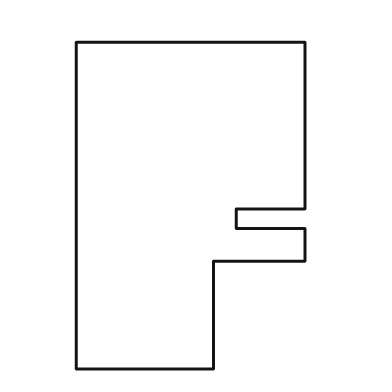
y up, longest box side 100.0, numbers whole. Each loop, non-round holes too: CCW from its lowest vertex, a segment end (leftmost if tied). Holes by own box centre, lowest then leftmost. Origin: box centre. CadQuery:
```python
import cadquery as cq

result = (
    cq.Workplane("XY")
    .moveTo(-35.0, -50.0)
    .lineTo(7.0, -50.0)
    .lineTo(7.0, -17.0)
    .lineTo(35.0, -17.0)
    .lineTo(35.0, -7.0)
    .lineTo(14.0, -7.0)
    .lineTo(14.0, -1.0)
    .lineTo(35.0, -1.0)
    .lineTo(35.0, 50.0)
    .lineTo(-35.0, 50.0)
    .close()
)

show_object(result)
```